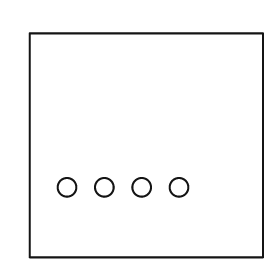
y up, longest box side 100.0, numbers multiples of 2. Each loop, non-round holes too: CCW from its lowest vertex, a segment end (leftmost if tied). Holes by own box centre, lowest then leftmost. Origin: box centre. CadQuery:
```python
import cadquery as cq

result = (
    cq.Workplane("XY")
    .moveTo(-50.0, -48.0)
    .lineTo(50.0, -48.0)
    .lineTo(50.0, 48.0)
    .lineTo(-50.0, 48.0)
    .close()
    .moveTo(-34.0, -18.0)
    .circle(4.0)
    .moveTo(-18.0, -18.0)
    .circle(4.0)
    .moveTo(-2.0, -18.0)
    .circle(4.0)
    .moveTo(14.0, -18.0)
    .circle(4.0)
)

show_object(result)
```